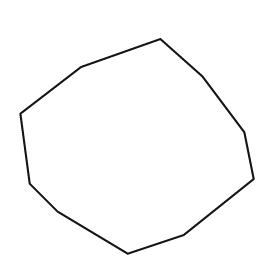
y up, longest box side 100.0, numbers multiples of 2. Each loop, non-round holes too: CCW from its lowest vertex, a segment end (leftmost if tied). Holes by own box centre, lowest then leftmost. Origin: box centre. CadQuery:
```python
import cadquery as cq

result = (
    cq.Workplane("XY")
    .moveTo(-4.0, -46.0)
    .lineTo(20.0, -38.0)
    .lineTo(50.0, -14.0)
    .lineTo(46.0, 6.0)
    .lineTo(28.0, 30.0)
    .lineTo(10.0, 46.0)
    .lineTo(-24.0, 34.0)
    .lineTo(-50.0, 14.0)
    .lineTo(-46.0, -16.0)
    .lineTo(-34.0, -28.0)
    .close()
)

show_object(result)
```